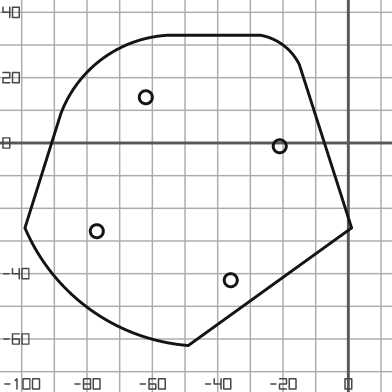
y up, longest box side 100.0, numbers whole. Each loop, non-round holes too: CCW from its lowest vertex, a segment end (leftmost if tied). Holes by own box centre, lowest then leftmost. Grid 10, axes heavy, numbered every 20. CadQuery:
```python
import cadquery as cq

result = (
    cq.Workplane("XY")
    .moveTo(-49.0, -62.0)
    .lineTo(1.0, -26.0)
    .lineTo(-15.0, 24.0)
    .threePointArc((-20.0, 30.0), (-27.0, 33.0))
    .lineTo(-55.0, 33.0)
    .threePointArc((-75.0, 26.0), (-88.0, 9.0))
    .lineTo(-99.0, -26.0)
    .threePointArc((-79.0, -51.0), (-49.0, -62.0))
    .close()
    .moveTo(-36.0, -42.0)
    .circle(2.0)
    .moveTo(-77.0, -27.0)
    .circle(2.0)
    .moveTo(-21.0, -1.0)
    .circle(2.0)
    .moveTo(-62.0, 14.0)
    .circle(2.0)
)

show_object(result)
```